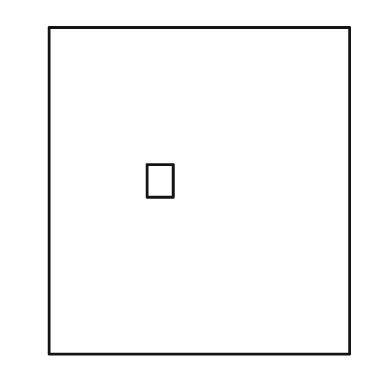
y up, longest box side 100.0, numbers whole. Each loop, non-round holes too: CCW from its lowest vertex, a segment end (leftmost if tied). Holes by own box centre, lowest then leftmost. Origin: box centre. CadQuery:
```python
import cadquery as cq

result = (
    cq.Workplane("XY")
    .moveTo(-46.0, -50.0)
    .lineTo(46.0, -50.0)
    .lineTo(46.0, 50.0)
    .lineTo(-46.0, 50.0)
    .close()
    .moveTo(-16.0, -2.0)
    .lineTo(-8.0, -2.0)
    .lineTo(-8.0, 8.0)
    .lineTo(-16.0, 8.0)
    .close()
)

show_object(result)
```